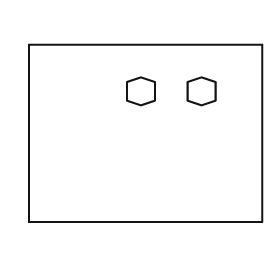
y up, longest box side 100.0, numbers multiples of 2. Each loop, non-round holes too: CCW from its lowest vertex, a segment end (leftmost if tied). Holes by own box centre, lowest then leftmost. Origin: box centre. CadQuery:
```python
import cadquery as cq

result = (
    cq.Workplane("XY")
    .moveTo(-50.0, -38.0)
    .lineTo(50.0, -38.0)
    .lineTo(50.0, 38.0)
    .lineTo(-50.0, 38.0)
    .close()
    .moveTo(-2.0, 12.0)
    .lineTo(4.0, 14.0)
    .lineTo(4.0, 22.0)
    .lineTo(-2.0, 24.0)
    .lineTo(-8.0, 22.0)
    .lineTo(-8.0, 14.0)
    .close()
    .moveTo(24.0, 12.0)
    .lineTo(30.0, 14.0)
    .lineTo(30.0, 22.0)
    .lineTo(24.0, 24.0)
    .lineTo(18.0, 22.0)
    .lineTo(18.0, 14.0)
    .close()
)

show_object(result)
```